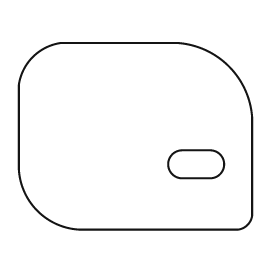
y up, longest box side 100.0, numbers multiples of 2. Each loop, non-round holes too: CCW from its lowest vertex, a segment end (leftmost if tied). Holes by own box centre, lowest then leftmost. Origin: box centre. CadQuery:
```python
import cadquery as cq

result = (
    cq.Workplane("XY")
    .moveTo(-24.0, -40.0)
    .lineTo(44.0, -40.0)
    .threePointArc((48.0, -38.0), (50.0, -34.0))
    .lineTo(50.0, 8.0)
    .threePointArc((40.0, 30.0), (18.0, 40.0))
    .lineTo(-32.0, 40.0)
    .threePointArc((-44.0, 34.0), (-50.0, 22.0))
    .lineTo(-50.0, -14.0)
    .threePointArc((-42.0, -32.0), (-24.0, -40.0))
    .close()
    .moveTo(20.0, -18.0)
    .lineTo(32.0, -18.0)
    .threePointArc((38.0, -12.0), (32.0, -6.0))
    .lineTo(20.0, -6.0)
    .threePointArc((14.0, -12.0), (20.0, -18.0))
    .close()
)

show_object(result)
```